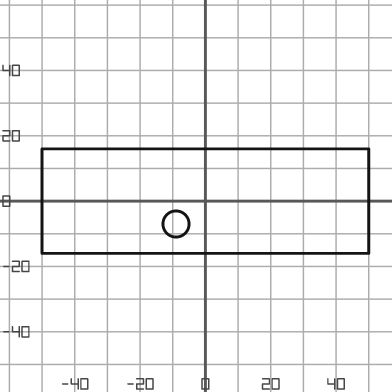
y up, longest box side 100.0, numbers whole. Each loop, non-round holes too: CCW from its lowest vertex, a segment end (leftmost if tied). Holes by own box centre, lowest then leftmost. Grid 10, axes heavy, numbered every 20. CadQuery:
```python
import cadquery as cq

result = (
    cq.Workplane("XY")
    .moveTo(-50.0, -16.0)
    .lineTo(50.0, -16.0)
    .lineTo(50.0, 16.0)
    .lineTo(-50.0, 16.0)
    .close()
    .moveTo(-9.0, -7.0)
    .circle(4.0)
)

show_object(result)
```